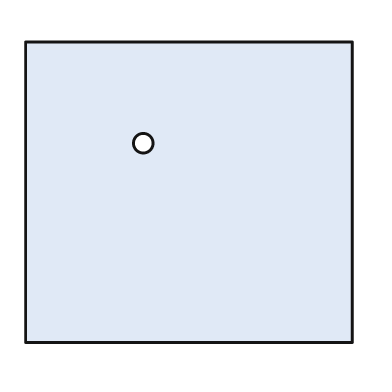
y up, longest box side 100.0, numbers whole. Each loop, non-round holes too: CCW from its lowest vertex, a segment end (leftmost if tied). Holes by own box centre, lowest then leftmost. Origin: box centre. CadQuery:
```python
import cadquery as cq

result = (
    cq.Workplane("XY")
    .moveTo(-50.0, -46.0)
    .lineTo(50.0, -46.0)
    .lineTo(50.0, 46.0)
    .lineTo(-50.0, 46.0)
    .close()
    .moveTo(-14.0, 15.0)
    .circle(3.0)
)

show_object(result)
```